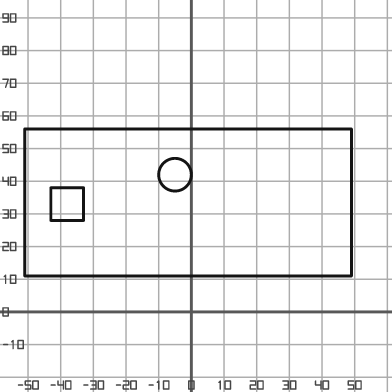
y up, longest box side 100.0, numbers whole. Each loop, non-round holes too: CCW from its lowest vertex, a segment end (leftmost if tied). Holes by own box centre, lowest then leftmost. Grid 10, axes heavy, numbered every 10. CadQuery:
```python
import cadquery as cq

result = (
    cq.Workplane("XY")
    .moveTo(-51.0, 11.0)
    .lineTo(49.0, 11.0)
    .lineTo(49.0, 56.0)
    .lineTo(-51.0, 56.0)
    .close()
    .moveTo(-43.0, 28.0)
    .lineTo(-33.0, 28.0)
    .lineTo(-33.0, 38.0)
    .lineTo(-43.0, 38.0)
    .close()
    .moveTo(-5.0, 42.0)
    .circle(5.0)
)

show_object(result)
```